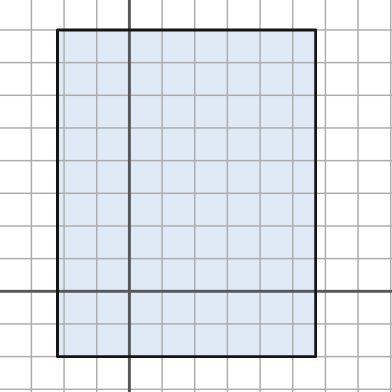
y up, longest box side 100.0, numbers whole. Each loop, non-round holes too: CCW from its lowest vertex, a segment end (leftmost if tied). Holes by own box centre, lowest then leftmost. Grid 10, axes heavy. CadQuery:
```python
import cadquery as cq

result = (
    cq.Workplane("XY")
    .moveTo(-22.0, -20.0)
    .lineTo(57.0, -20.0)
    .lineTo(57.0, 80.0)
    .lineTo(-22.0, 80.0)
    .close()
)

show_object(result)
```